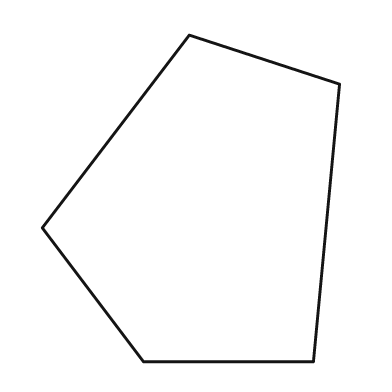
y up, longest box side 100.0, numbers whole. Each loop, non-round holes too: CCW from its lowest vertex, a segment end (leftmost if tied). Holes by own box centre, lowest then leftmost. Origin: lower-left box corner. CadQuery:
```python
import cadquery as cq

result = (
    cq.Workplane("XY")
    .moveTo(31.0, 0.0)
    .lineTo(83.0, 0.0)
    .lineTo(91.0, 85.0)
    .lineTo(45.0, 100.0)
    .lineTo(0.0, 41.0)
    .close()
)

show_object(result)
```